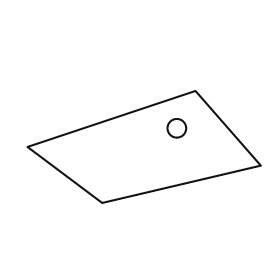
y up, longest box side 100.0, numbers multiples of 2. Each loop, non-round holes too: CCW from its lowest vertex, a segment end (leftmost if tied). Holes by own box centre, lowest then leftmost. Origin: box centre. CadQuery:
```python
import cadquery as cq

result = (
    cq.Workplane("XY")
    .moveTo(-18.0, -24.0)
    .lineTo(50.0, -8.0)
    .lineTo(22.0, 24.0)
    .lineTo(-50.0, 0.0)
    .close()
    .moveTo(14.0, 8.0)
    .circle(4.0)
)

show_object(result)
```